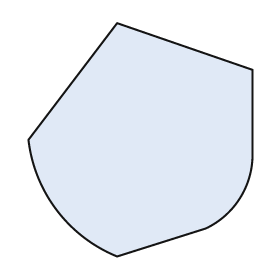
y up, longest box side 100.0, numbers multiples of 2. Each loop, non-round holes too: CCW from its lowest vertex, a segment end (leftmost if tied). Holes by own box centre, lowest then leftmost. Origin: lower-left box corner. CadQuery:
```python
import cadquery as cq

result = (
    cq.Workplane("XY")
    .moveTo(38.0, 0.0)
    .lineTo(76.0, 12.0)
    .threePointArc((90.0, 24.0), (96.0, 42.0))
    .lineTo(96.0, 80.0)
    .lineTo(38.0, 100.0)
    .lineTo(0.0, 50.0)
    .threePointArc((12.0, 20.0), (38.0, 0.0))
    .close()
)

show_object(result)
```